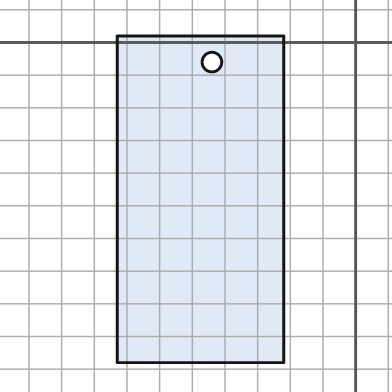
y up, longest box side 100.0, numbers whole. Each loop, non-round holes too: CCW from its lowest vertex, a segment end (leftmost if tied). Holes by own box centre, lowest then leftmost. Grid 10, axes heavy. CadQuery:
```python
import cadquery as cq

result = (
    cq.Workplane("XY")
    .moveTo(-73.0, -98.0)
    .lineTo(-22.0, -98.0)
    .lineTo(-22.0, 2.0)
    .lineTo(-73.0, 2.0)
    .close()
    .moveTo(-44.0, -6.0)
    .circle(3.0)
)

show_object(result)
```